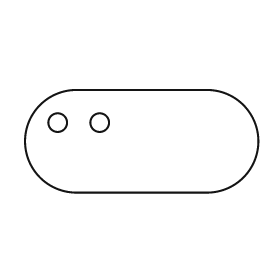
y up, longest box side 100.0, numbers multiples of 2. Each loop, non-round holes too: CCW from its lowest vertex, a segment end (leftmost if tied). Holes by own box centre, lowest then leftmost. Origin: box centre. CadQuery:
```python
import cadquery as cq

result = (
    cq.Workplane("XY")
    .moveTo(-28.0, -22.0)
    .lineTo(28.0, -22.0)
    .threePointArc((50.0, 0.0), (28.0, 22.0))
    .lineTo(-28.0, 22.0)
    .threePointArc((-50.0, 0.0), (-28.0, -22.0))
    .close()
    .moveTo(-36.0, 8.0)
    .circle(4.0)
    .moveTo(-18.0, 8.0)
    .circle(4.0)
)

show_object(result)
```